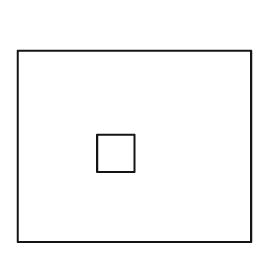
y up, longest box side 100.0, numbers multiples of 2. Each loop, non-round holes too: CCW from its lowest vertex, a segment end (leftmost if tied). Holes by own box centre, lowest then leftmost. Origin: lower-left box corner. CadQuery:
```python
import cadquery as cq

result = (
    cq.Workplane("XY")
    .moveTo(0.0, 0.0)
    .lineTo(100.0, 0.0)
    .lineTo(100.0, 82.0)
    .lineTo(0.0, 82.0)
    .close()
    .moveTo(34.0, 30.0)
    .lineTo(50.0, 30.0)
    .lineTo(50.0, 46.0)
    .lineTo(34.0, 46.0)
    .close()
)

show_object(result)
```